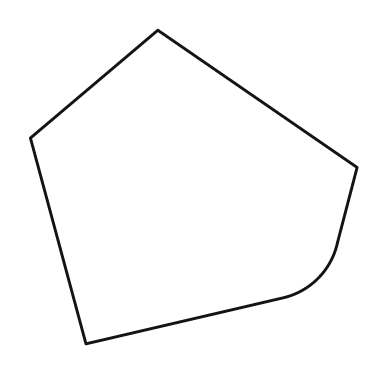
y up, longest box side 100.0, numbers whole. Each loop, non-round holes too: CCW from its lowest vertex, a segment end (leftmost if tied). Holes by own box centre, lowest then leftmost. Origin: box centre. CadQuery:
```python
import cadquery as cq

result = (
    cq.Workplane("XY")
    .moveTo(-33.0, -48.0)
    .lineTo(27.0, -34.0)
    .threePointArc((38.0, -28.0), (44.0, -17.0))
    .lineTo(50.0, 6.0)
    .lineTo(-11.0, 48.0)
    .lineTo(-50.0, 15.0)
    .close()
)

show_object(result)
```